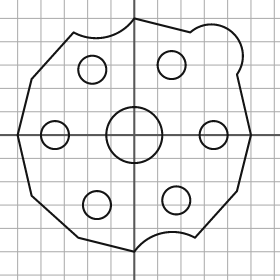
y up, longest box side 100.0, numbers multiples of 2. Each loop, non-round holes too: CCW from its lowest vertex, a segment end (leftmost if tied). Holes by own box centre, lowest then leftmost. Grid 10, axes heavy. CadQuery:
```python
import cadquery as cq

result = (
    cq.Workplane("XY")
    .moveTo(0.0, -50.0)
    .threePointArc((12.0, -42.0), (26.0, -44.0))
    .lineTo(44.0, -24.0)
    .lineTo(50.0, 0.0)
    .lineTo(44.0, 26.0)
    .threePointArc((42.0, 44.0), (24.0, 44.0))
    .lineTo(0.0, 50.0)
    .threePointArc((-12.0, 42.0), (-26.0, 44.0))
    .lineTo(-44.0, 24.0)
    .lineTo(-50.0, 0.0)
    .lineTo(-44.0, -26.0)
    .lineTo(-24.0, -44.0)
    .close()
    .moveTo(-16.0, -30.0)
    .circle(6.0)
    .moveTo(18.0, -28.0)
    .circle(6.0)
    .moveTo(-34.0, 0.0)
    .circle(6.0)
    .moveTo(0.0, 0.0)
    .circle(12.0)
    .moveTo(34.0, 0.0)
    .circle(6.0)
    .moveTo(-18.0, 28.0)
    .circle(6.0)
    .moveTo(16.0, 30.0)
    .circle(6.0)
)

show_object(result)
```